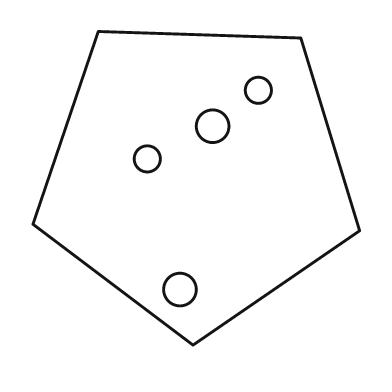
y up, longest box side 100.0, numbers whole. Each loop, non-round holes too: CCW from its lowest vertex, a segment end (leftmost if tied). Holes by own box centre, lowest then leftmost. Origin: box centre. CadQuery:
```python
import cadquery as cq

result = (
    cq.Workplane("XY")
    .moveTo(-1.0, -48.0)
    .lineTo(50.0, -13.0)
    .lineTo(32.0, 46.0)
    .lineTo(-30.0, 48.0)
    .lineTo(-50.0, -11.0)
    .close()
    .moveTo(-5.0, -31.0)
    .circle(5.0)
    .moveTo(-15.0, 9.0)
    .circle(4.0)
    .moveTo(5.0, 19.0)
    .circle(5.0)
    .moveTo(19.0, 30.0)
    .circle(4.0)
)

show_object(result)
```